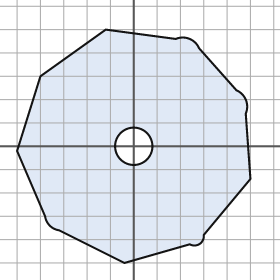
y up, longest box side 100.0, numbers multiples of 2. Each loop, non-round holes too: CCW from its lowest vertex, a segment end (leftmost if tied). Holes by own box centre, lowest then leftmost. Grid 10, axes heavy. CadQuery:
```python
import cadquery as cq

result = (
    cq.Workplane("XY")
    .moveTo(-4.0, -50.0)
    .lineTo(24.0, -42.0)
    .threePointArc((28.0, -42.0), (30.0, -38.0))
    .lineTo(50.0, -14.0)
    .lineTo(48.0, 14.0)
    .threePointArc((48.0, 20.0), (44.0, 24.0))
    .lineTo(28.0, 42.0)
    .threePointArc((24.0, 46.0), (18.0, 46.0))
    .lineTo(-12.0, 50.0)
    .lineTo(-40.0, 30.0)
    .lineTo(-50.0, -2.0)
    .lineTo(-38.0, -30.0)
    .threePointArc((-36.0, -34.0), (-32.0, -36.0))
    .close()
    .moveTo(0.0, 0.0)
    .circle(8.0)
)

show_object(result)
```